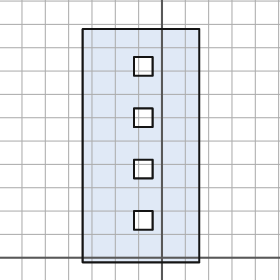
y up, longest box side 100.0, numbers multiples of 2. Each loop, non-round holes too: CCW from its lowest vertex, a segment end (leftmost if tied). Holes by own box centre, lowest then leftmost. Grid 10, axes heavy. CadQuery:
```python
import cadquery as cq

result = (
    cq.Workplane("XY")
    .moveTo(-34.0, -2.0)
    .lineTo(16.0, -2.0)
    .lineTo(16.0, 98.0)
    .lineTo(-34.0, 98.0)
    .close()
    .moveTo(-12.0, 12.0)
    .lineTo(-4.0, 12.0)
    .lineTo(-4.0, 20.0)
    .lineTo(-12.0, 20.0)
    .close()
    .moveTo(-12.0, 34.0)
    .lineTo(-4.0, 34.0)
    .lineTo(-4.0, 42.0)
    .lineTo(-12.0, 42.0)
    .close()
    .moveTo(-12.0, 56.0)
    .lineTo(-4.0, 56.0)
    .lineTo(-4.0, 64.0)
    .lineTo(-12.0, 64.0)
    .close()
    .moveTo(-12.0, 78.0)
    .lineTo(-4.0, 78.0)
    .lineTo(-4.0, 86.0)
    .lineTo(-12.0, 86.0)
    .close()
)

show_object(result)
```